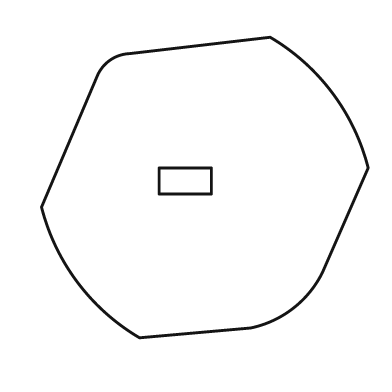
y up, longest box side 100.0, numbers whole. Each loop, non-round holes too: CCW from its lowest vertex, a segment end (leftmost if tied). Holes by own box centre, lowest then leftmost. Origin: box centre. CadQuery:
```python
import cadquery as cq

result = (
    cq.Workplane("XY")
    .moveTo(-20.0, -46.0)
    .lineTo(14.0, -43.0)
    .threePointArc((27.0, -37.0), (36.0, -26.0))
    .lineTo(50.0, 6.0)
    .threePointArc((39.0, 29.0), (20.0, 46.0))
    .lineTo(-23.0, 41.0)
    .threePointArc((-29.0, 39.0), (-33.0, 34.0))
    .lineTo(-50.0, -6.0)
    .threePointArc((-39.0, -29.0), (-20.0, -46.0))
    .close()
    .moveTo(-14.0, -2.0)
    .lineTo(2.0, -2.0)
    .lineTo(2.0, 6.0)
    .lineTo(-14.0, 6.0)
    .close()
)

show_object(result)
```